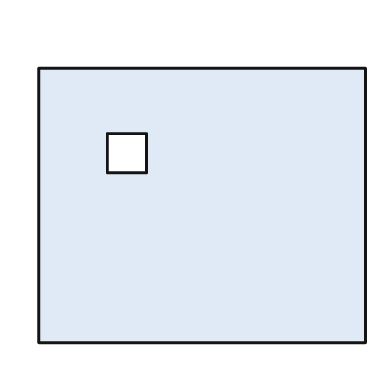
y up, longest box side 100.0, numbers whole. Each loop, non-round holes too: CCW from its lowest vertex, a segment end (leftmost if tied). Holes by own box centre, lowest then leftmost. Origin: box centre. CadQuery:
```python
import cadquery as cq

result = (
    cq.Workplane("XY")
    .moveTo(-50.0, -42.0)
    .lineTo(50.0, -42.0)
    .lineTo(50.0, 42.0)
    .lineTo(-50.0, 42.0)
    .close()
    .moveTo(-29.0, 10.0)
    .lineTo(-17.0, 10.0)
    .lineTo(-17.0, 22.0)
    .lineTo(-29.0, 22.0)
    .close()
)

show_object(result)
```